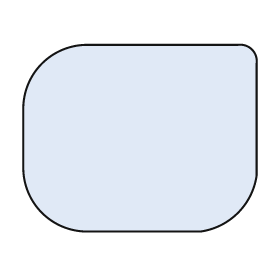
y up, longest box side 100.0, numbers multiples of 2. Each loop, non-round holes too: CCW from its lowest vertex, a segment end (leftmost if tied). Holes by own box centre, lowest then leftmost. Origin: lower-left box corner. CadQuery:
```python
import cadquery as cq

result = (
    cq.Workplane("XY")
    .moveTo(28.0, 0.0)
    .lineTo(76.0, 0.0)
    .threePointArc((92.0, 8.0), (100.0, 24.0))
    .lineTo(100.0, 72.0)
    .threePointArc((98.0, 78.0), (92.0, 80.0))
    .lineTo(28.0, 80.0)
    .threePointArc((8.0, 72.0), (0.0, 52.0))
    .lineTo(0.0, 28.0)
    .threePointArc((8.0, 8.0), (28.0, 0.0))
    .close()
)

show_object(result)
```